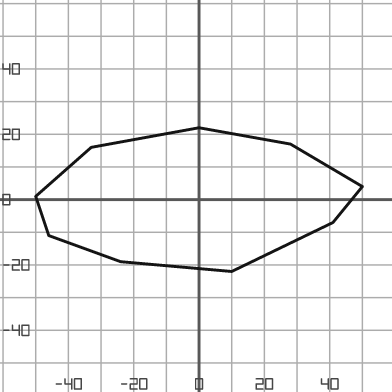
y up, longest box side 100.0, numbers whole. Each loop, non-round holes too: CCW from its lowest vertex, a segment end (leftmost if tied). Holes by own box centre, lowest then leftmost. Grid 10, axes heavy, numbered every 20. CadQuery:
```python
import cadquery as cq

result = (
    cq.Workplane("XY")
    .moveTo(10.0, -22.0)
    .lineTo(41.0, -7.0)
    .lineTo(50.0, 4.0)
    .lineTo(28.0, 17.0)
    .lineTo(0.0, 22.0)
    .lineTo(-33.0, 16.0)
    .lineTo(-50.0, 1.0)
    .lineTo(-46.0, -11.0)
    .lineTo(-24.0, -19.0)
    .close()
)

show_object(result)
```